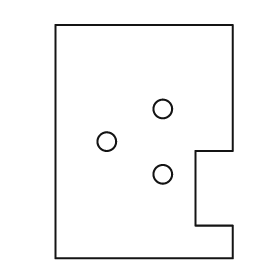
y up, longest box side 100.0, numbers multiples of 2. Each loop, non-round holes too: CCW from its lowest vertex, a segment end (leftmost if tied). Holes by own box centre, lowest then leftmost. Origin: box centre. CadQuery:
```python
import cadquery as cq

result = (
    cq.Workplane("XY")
    .moveTo(-38.0, -50.0)
    .lineTo(38.0, -50.0)
    .lineTo(38.0, -36.0)
    .lineTo(22.0, -36.0)
    .lineTo(22.0, -4.0)
    .lineTo(38.0, -4.0)
    .lineTo(38.0, 50.0)
    .lineTo(-38.0, 50.0)
    .close()
    .moveTo(8.0, -14.0)
    .circle(4.0)
    .moveTo(-16.0, 0.0)
    .circle(4.0)
    .moveTo(8.0, 14.0)
    .circle(4.0)
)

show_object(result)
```